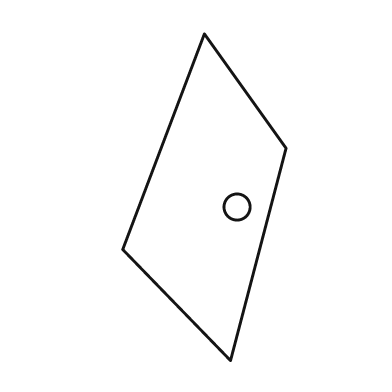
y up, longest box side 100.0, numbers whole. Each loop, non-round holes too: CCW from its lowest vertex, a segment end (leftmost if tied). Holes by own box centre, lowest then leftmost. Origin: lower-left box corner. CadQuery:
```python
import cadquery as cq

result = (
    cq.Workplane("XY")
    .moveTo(33.0, 0.0)
    .lineTo(50.0, 65.0)
    .lineTo(25.0, 100.0)
    .lineTo(0.0, 34.0)
    .close()
    .moveTo(35.0, 47.0)
    .circle(4.0)
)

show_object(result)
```